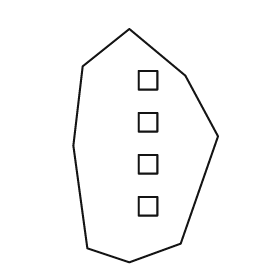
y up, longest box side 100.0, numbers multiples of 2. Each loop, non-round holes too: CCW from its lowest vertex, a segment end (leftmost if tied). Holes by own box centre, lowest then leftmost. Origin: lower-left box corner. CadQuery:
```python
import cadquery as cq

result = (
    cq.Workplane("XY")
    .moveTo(24.0, 0.0)
    .lineTo(46.0, 8.0)
    .lineTo(62.0, 54.0)
    .lineTo(48.0, 80.0)
    .lineTo(24.0, 100.0)
    .lineTo(4.0, 84.0)
    .lineTo(0.0, 50.0)
    .lineTo(6.0, 6.0)
    .close()
    .moveTo(28.0, 20.0)
    .lineTo(36.0, 20.0)
    .lineTo(36.0, 28.0)
    .lineTo(28.0, 28.0)
    .close()
    .moveTo(28.0, 38.0)
    .lineTo(36.0, 38.0)
    .lineTo(36.0, 46.0)
    .lineTo(28.0, 46.0)
    .close()
    .moveTo(28.0, 56.0)
    .lineTo(36.0, 56.0)
    .lineTo(36.0, 64.0)
    .lineTo(28.0, 64.0)
    .close()
    .moveTo(28.0, 74.0)
    .lineTo(36.0, 74.0)
    .lineTo(36.0, 82.0)
    .lineTo(28.0, 82.0)
    .close()
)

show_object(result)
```